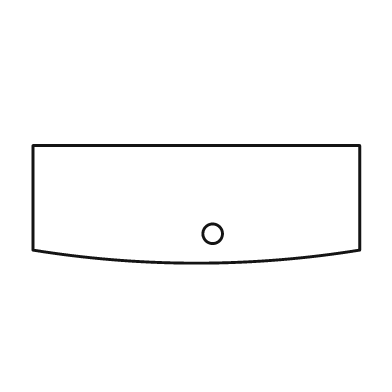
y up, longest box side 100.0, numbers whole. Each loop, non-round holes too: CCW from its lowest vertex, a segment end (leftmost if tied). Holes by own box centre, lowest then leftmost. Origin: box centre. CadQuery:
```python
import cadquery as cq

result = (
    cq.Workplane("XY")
    .moveTo(-50.0, -14.0)
    .threePointArc((0.0, -18.0), (50.0, -14.0))
    .lineTo(50.0, 18.0)
    .lineTo(-50.0, 18.0)
    .close()
    .moveTo(5.0, -9.0)
    .circle(3.0)
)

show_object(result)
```